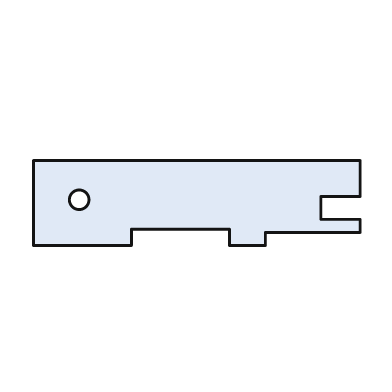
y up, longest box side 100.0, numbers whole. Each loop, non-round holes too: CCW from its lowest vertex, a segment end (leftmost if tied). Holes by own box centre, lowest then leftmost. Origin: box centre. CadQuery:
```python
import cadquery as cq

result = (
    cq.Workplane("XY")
    .moveTo(-50.0, -13.0)
    .lineTo(-20.0, -13.0)
    .lineTo(-20.0, -8.0)
    .lineTo(10.0, -8.0)
    .lineTo(10.0, -13.0)
    .lineTo(21.0, -13.0)
    .lineTo(21.0, -9.0)
    .lineTo(50.0, -9.0)
    .lineTo(50.0, -5.0)
    .lineTo(38.0, -5.0)
    .lineTo(38.0, 2.0)
    .lineTo(50.0, 2.0)
    .lineTo(50.0, 13.0)
    .lineTo(-50.0, 13.0)
    .close()
    .moveTo(-36.0, 1.0)
    .circle(3.0)
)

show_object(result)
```